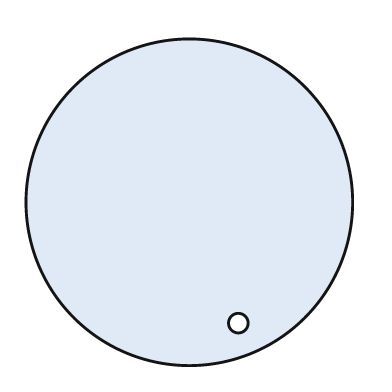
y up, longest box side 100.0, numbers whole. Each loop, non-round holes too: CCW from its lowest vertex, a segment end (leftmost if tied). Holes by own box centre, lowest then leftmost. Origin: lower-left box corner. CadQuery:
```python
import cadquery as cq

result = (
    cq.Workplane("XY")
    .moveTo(50.0, 50.0)
    .circle(50.0)
    .moveTo(65.0, 13.0)
    .circle(3.0)
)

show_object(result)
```